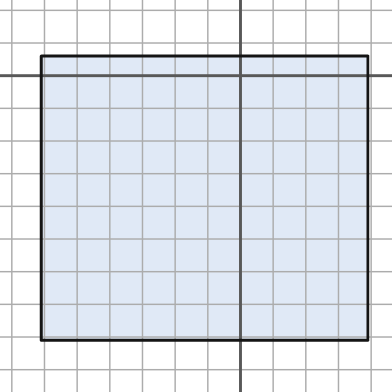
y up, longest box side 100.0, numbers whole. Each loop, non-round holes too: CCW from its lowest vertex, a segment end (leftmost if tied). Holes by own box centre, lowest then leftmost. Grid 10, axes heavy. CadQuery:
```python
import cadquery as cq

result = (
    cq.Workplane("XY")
    .moveTo(-61.0, -81.0)
    .lineTo(39.0, -81.0)
    .lineTo(39.0, 6.0)
    .lineTo(-61.0, 6.0)
    .close()
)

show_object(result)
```